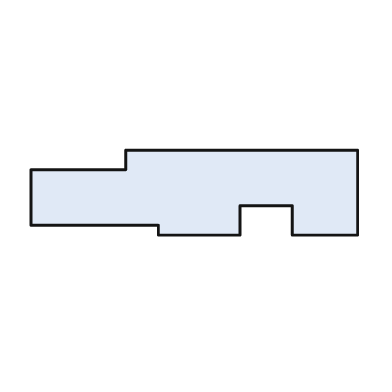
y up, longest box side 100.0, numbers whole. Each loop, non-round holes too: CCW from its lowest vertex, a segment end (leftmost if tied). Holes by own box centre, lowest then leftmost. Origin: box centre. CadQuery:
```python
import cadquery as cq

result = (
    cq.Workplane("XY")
    .moveTo(-11.0, -13.0)
    .lineTo(14.0, -13.0)
    .lineTo(14.0, -4.0)
    .lineTo(30.0, -4.0)
    .lineTo(30.0, -13.0)
    .lineTo(50.0, -13.0)
    .lineTo(50.0, 13.0)
    .lineTo(-21.0, 13.0)
    .lineTo(-21.0, 7.0)
    .lineTo(-50.0, 7.0)
    .lineTo(-50.0, -10.0)
    .lineTo(-11.0, -10.0)
    .close()
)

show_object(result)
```